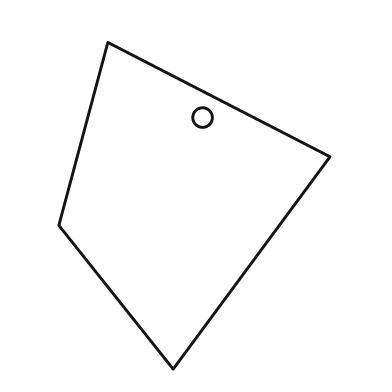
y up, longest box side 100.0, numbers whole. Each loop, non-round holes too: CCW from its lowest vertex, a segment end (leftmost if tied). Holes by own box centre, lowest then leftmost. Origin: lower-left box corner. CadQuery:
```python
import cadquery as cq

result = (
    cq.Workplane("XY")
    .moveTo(35.0, 0.0)
    .lineTo(83.0, 65.0)
    .lineTo(15.0, 100.0)
    .lineTo(0.0, 44.0)
    .close()
    .moveTo(44.0, 77.0)
    .circle(3.0)
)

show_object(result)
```